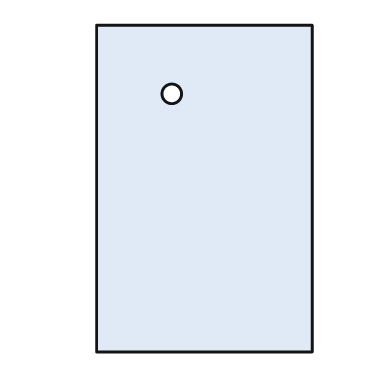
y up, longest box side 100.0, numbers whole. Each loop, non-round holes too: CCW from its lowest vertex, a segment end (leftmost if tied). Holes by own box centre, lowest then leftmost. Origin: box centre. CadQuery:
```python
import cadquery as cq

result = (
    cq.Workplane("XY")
    .moveTo(-33.0, -50.0)
    .lineTo(33.0, -50.0)
    .lineTo(33.0, 50.0)
    .lineTo(-33.0, 50.0)
    .close()
    .moveTo(-10.0, 29.0)
    .circle(3.0)
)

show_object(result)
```